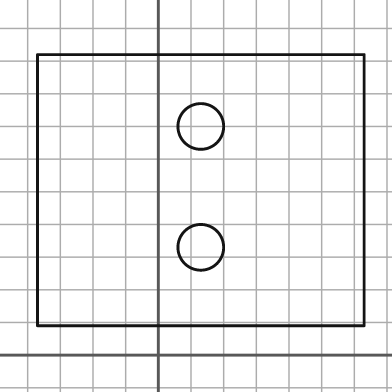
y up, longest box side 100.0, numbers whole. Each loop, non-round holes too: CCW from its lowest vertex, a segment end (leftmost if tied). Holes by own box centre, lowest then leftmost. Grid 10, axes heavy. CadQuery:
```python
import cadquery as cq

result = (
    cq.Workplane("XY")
    .moveTo(-37.0, 9.0)
    .lineTo(63.0, 9.0)
    .lineTo(63.0, 92.0)
    .lineTo(-37.0, 92.0)
    .close()
    .moveTo(13.0, 33.0)
    .circle(7.0)
    .moveTo(13.0, 70.0)
    .circle(7.0)
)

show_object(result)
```